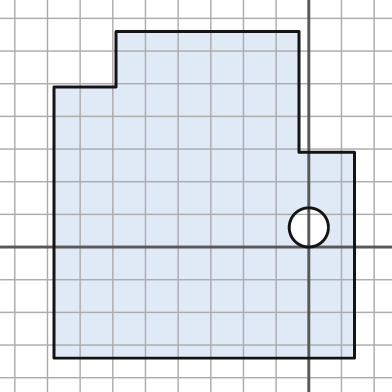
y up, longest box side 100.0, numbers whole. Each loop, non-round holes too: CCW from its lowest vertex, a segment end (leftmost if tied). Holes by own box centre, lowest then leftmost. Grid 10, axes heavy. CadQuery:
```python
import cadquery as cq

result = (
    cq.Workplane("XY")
    .moveTo(-78.0, -34.0)
    .lineTo(14.0, -34.0)
    .lineTo(14.0, 29.0)
    .lineTo(-3.0, 29.0)
    .lineTo(-3.0, 66.0)
    .lineTo(-59.0, 66.0)
    .lineTo(-59.0, 49.0)
    .lineTo(-78.0, 49.0)
    .close()
    .moveTo(0.0, 6.0)
    .circle(6.0)
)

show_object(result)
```